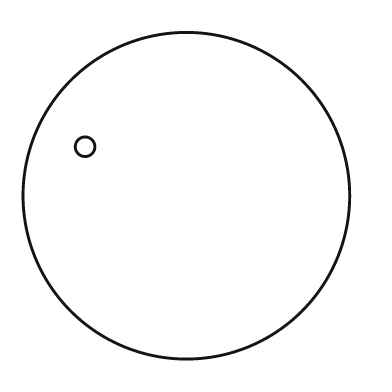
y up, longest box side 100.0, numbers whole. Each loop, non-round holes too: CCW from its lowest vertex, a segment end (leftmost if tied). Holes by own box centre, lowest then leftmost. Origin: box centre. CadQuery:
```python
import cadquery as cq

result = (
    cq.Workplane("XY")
    .moveTo(0.0, 0.0)
    .circle(50.0)
    .moveTo(-31.0, 15.0)
    .circle(3.0)
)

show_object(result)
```